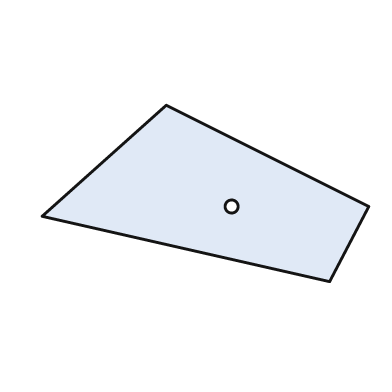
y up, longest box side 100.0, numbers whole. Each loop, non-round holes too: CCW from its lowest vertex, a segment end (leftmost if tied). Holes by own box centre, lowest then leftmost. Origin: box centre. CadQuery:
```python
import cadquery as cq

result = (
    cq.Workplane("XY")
    .moveTo(38.0, -27.0)
    .lineTo(50.0, -4.0)
    .lineTo(-12.0, 27.0)
    .lineTo(-50.0, -7.0)
    .close()
    .moveTo(8.0, -4.0)
    .circle(2.0)
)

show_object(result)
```